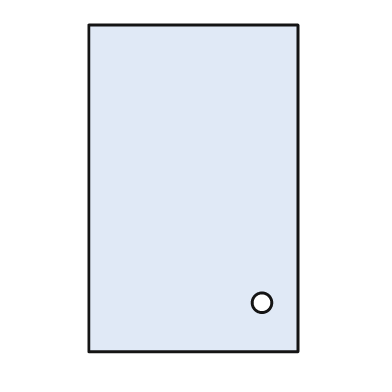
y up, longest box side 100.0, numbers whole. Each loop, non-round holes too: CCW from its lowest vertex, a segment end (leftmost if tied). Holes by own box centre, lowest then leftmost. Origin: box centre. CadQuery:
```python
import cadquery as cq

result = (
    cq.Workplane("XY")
    .moveTo(-32.0, -50.0)
    .lineTo(32.0, -50.0)
    .lineTo(32.0, 50.0)
    .lineTo(-32.0, 50.0)
    .close()
    .moveTo(21.0, -35.0)
    .circle(3.0)
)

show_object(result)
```